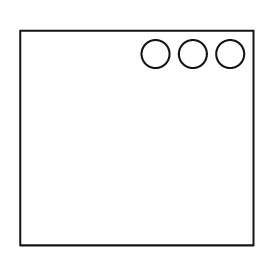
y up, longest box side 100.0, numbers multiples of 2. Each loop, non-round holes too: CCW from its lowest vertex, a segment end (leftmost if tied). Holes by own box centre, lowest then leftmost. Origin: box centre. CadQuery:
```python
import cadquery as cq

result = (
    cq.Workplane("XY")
    .moveTo(-50.0, -46.0)
    .lineTo(50.0, -46.0)
    .lineTo(50.0, 46.0)
    .lineTo(-50.0, 46.0)
    .close()
    .moveTo(8.0, 36.0)
    .circle(6.0)
    .moveTo(24.0, 36.0)
    .circle(6.0)
    .moveTo(40.0, 36.0)
    .circle(6.0)
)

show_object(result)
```